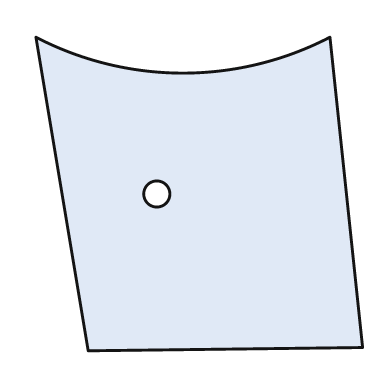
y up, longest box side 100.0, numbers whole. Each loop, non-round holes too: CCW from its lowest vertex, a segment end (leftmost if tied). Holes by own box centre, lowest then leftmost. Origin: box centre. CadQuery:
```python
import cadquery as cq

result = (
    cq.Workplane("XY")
    .moveTo(-34.0, -48.0)
    .lineTo(50.0, -47.0)
    .lineTo(40.0, 48.0)
    .threePointArc((-5.0, 37.0), (-50.0, 48.0))
    .close()
    .moveTo(-13.0, 0.0)
    .circle(4.0)
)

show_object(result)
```